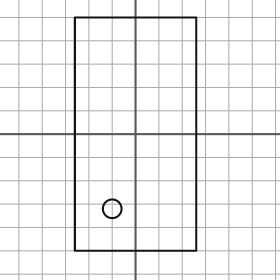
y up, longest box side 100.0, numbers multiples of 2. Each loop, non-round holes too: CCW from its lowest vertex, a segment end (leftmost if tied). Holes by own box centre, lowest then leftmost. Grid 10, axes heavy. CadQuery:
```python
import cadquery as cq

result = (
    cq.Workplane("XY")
    .moveTo(-26.0, -50.0)
    .lineTo(26.0, -50.0)
    .lineTo(26.0, 50.0)
    .lineTo(-26.0, 50.0)
    .close()
    .moveTo(-10.0, -32.0)
    .circle(4.0)
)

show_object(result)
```